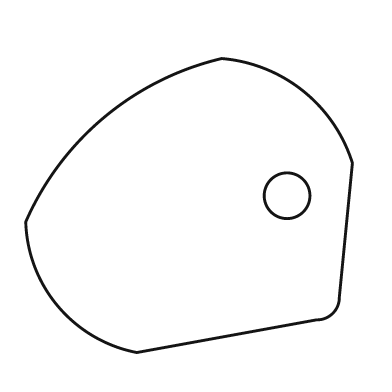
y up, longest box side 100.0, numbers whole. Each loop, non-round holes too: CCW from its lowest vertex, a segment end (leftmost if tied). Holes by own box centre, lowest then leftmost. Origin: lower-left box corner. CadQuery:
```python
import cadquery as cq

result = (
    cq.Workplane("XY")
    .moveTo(34.0, 0.0)
    .lineTo(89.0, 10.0)
    .threePointArc((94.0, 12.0), (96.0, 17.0))
    .lineTo(100.0, 58.0)
    .threePointArc((85.0, 80.0), (60.0, 90.0))
    .threePointArc((24.0, 72.0), (0.0, 40.0))
    .threePointArc((10.0, 14.0), (34.0, 0.0))
    .close()
    .moveTo(80.0, 48.0)
    .circle(7.0)
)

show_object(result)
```